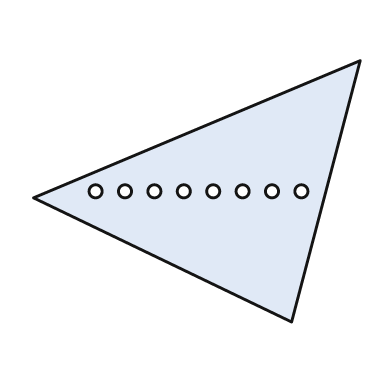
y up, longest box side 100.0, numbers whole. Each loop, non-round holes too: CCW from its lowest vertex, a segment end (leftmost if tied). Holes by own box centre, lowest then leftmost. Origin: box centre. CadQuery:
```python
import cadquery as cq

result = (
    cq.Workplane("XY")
    .moveTo(29.0, -40.0)
    .lineTo(50.0, 40.0)
    .lineTo(-50.0, -2.0)
    .close()
    .moveTo(-31.0, 0.0)
    .circle(2.0)
    .moveTo(-22.0, 0.0)
    .circle(2.0)
    .moveTo(-13.0, 0.0)
    .circle(2.0)
    .moveTo(-4.0, 0.0)
    .circle(2.0)
    .moveTo(5.0, 0.0)
    .circle(2.0)
    .moveTo(14.0, 0.0)
    .circle(2.0)
    .moveTo(23.0, 0.0)
    .circle(2.0)
    .moveTo(32.0, 0.0)
    .circle(2.0)
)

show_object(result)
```